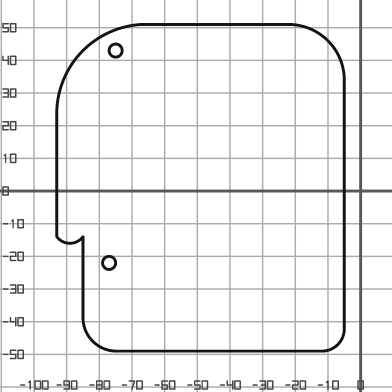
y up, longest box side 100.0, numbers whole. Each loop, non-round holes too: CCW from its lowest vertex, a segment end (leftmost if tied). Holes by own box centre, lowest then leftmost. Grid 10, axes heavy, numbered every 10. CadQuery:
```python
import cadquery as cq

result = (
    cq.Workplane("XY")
    .moveTo(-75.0, -49.0)
    .lineTo(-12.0, -49.0)
    .threePointArc((-7.0, -47.0), (-5.0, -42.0))
    .lineTo(-5.0, 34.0)
    .threePointArc((-10.0, 46.0), (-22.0, 51.0))
    .lineTo(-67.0, 51.0)
    .threePointArc((-85.0, 43.0), (-93.0, 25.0))
    .lineTo(-93.0, -14.0)
    .threePointArc((-89.0, -16.0), (-85.0, -14.0))
    .lineTo(-85.0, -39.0)
    .threePointArc((-82.0, -46.0), (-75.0, -49.0))
    .close()
    .moveTo(-77.0, -22.0)
    .circle(2.0)
    .moveTo(-75.0, 43.0)
    .circle(2.0)
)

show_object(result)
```